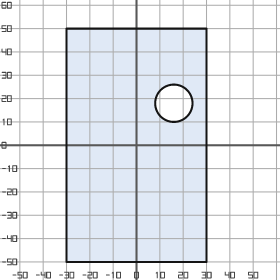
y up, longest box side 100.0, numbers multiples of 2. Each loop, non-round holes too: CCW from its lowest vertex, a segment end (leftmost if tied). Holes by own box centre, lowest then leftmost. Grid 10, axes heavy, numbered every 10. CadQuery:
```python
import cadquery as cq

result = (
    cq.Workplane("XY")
    .moveTo(-30.0, -50.0)
    .lineTo(30.0, -50.0)
    .lineTo(30.0, 50.0)
    .lineTo(-30.0, 50.0)
    .close()
    .moveTo(16.0, 18.0)
    .circle(8.0)
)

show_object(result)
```